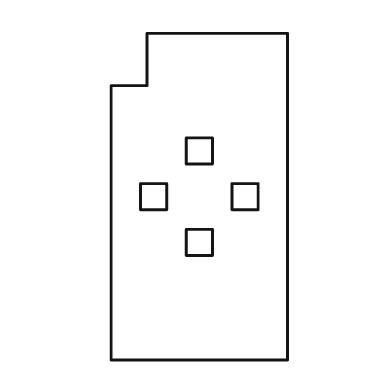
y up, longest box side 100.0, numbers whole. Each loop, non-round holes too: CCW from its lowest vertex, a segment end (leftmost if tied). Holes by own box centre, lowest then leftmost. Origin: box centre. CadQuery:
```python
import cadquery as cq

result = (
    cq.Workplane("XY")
    .moveTo(-27.0, -50.0)
    .lineTo(27.0, -50.0)
    .lineTo(27.0, 50.0)
    .lineTo(-16.0, 50.0)
    .lineTo(-16.0, 34.0)
    .lineTo(-27.0, 34.0)
    .close()
    .moveTo(-4.0, -18.0)
    .lineTo(4.0, -18.0)
    .lineTo(4.0, -10.0)
    .lineTo(-4.0, -10.0)
    .close()
    .moveTo(-18.0, -4.0)
    .lineTo(-10.0, -4.0)
    .lineTo(-10.0, 4.0)
    .lineTo(-18.0, 4.0)
    .close()
    .moveTo(10.0, -4.0)
    .lineTo(18.0, -4.0)
    .lineTo(18.0, 4.0)
    .lineTo(10.0, 4.0)
    .close()
    .moveTo(-4.0, 10.0)
    .lineTo(4.0, 10.0)
    .lineTo(4.0, 18.0)
    .lineTo(-4.0, 18.0)
    .close()
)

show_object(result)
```